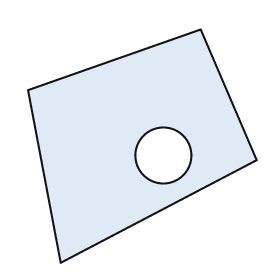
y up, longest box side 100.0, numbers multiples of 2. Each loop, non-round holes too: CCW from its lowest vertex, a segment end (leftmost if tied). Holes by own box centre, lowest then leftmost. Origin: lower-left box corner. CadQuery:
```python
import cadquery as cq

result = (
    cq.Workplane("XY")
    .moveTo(14.0, 0.0)
    .lineTo(98.0, 44.0)
    .lineTo(74.0, 100.0)
    .lineTo(0.0, 74.0)
    .close()
    .moveTo(58.0, 46.0)
    .circle(12.0)
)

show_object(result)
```